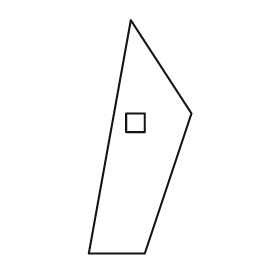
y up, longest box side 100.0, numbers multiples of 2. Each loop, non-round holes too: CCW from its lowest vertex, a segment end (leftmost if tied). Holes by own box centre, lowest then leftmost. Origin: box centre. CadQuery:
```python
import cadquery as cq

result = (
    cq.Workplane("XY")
    .moveTo(-22.0, -50.0)
    .lineTo(2.0, -50.0)
    .lineTo(22.0, 10.0)
    .lineTo(-4.0, 50.0)
    .close()
    .moveTo(-6.0, 2.0)
    .lineTo(2.0, 2.0)
    .lineTo(2.0, 10.0)
    .lineTo(-6.0, 10.0)
    .close()
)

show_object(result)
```